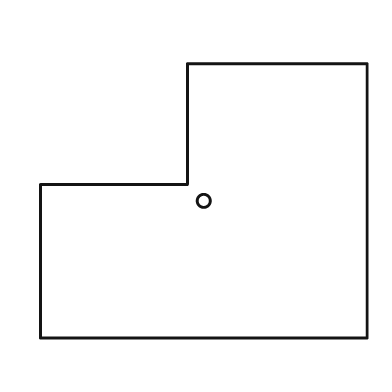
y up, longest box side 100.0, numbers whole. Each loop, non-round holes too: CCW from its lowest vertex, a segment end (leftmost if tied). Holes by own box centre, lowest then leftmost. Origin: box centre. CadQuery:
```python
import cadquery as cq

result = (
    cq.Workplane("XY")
    .moveTo(-50.0, -42.0)
    .lineTo(50.0, -42.0)
    .lineTo(50.0, 42.0)
    .lineTo(-5.0, 42.0)
    .lineTo(-5.0, 5.0)
    .lineTo(-50.0, 5.0)
    .close()
    .moveTo(0.0, 0.0)
    .circle(2.0)
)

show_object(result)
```